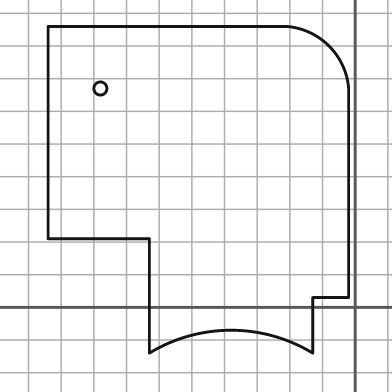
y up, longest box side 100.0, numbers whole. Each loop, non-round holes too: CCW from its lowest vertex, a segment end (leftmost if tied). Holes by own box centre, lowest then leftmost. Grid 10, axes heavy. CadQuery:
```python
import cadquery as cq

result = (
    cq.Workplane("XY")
    .moveTo(-63.0, -14.0)
    .threePointArc((-38.0, -7.0), (-13.0, -14.0))
    .lineTo(-13.0, 3.0)
    .lineTo(-2.0, 3.0)
    .lineTo(-2.0, 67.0)
    .threePointArc((-8.0, 80.0), (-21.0, 86.0))
    .lineTo(-94.0, 86.0)
    .lineTo(-94.0, 21.0)
    .lineTo(-63.0, 21.0)
    .close()
    .moveTo(-78.0, 67.0)
    .circle(2.0)
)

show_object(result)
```